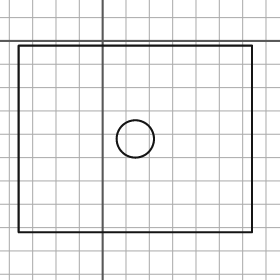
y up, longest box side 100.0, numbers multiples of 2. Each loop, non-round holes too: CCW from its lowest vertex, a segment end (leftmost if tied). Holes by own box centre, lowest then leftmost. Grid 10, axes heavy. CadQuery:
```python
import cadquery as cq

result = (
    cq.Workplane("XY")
    .moveTo(-36.0, -82.0)
    .lineTo(64.0, -82.0)
    .lineTo(64.0, -2.0)
    .lineTo(-36.0, -2.0)
    .close()
    .moveTo(14.0, -42.0)
    .circle(8.0)
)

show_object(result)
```